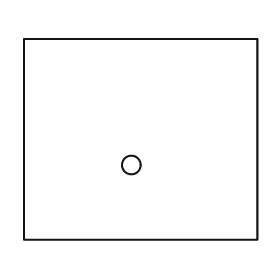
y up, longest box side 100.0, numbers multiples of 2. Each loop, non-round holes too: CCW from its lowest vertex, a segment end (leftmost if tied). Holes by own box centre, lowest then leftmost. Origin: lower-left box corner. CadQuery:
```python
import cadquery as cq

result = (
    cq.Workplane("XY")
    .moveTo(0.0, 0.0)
    .lineTo(100.0, 0.0)
    .lineTo(100.0, 86.0)
    .lineTo(0.0, 86.0)
    .close()
    .moveTo(46.0, 32.0)
    .circle(4.0)
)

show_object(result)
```